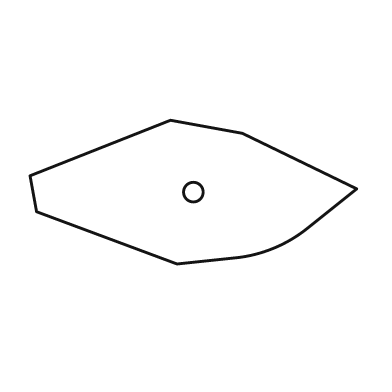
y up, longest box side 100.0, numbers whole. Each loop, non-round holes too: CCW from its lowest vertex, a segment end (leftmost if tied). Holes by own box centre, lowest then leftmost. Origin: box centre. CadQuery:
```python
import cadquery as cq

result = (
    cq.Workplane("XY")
    .moveTo(-5.0, -22.0)
    .lineTo(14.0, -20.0)
    .threePointArc((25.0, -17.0), (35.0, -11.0))
    .lineTo(50.0, 1.0)
    .lineTo(15.0, 18.0)
    .lineTo(-7.0, 22.0)
    .lineTo(-50.0, 5.0)
    .lineTo(-48.0, -6.0)
    .close()
    .moveTo(0.0, 0.0)
    .circle(3.0)
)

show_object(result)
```